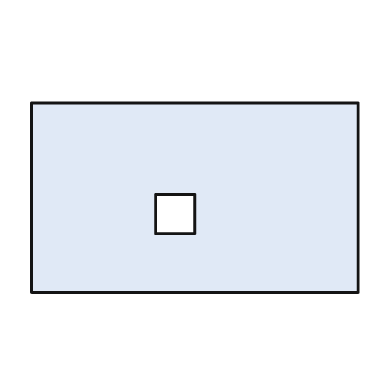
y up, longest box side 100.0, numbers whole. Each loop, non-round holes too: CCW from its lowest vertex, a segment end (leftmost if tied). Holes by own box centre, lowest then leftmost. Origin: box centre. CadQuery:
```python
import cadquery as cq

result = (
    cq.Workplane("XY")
    .moveTo(-50.0, -29.0)
    .lineTo(50.0, -29.0)
    .lineTo(50.0, 29.0)
    .lineTo(-50.0, 29.0)
    .close()
    .moveTo(-12.0, -11.0)
    .lineTo(0.0, -11.0)
    .lineTo(0.0, 1.0)
    .lineTo(-12.0, 1.0)
    .close()
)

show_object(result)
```